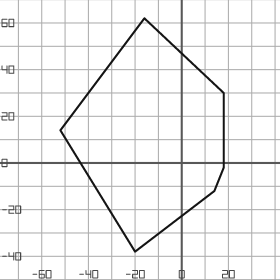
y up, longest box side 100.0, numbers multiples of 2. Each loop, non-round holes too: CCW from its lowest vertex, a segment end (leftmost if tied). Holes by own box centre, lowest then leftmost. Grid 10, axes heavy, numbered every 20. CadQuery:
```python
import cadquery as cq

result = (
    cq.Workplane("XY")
    .moveTo(-20.0, -38.0)
    .lineTo(14.0, -12.0)
    .lineTo(18.0, -2.0)
    .lineTo(18.0, 30.0)
    .lineTo(-16.0, 62.0)
    .lineTo(-52.0, 14.0)
    .close()
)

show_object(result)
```